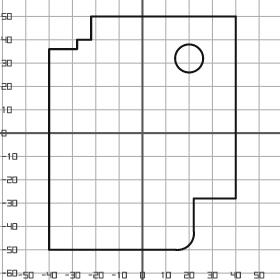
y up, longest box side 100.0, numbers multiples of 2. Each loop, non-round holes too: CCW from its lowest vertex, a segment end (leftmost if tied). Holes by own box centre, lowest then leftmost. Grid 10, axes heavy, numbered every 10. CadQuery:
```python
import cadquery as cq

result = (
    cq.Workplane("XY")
    .moveTo(-40.0, -50.0)
    .lineTo(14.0, -50.0)
    .threePointArc((20.0, -48.0), (22.0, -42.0))
    .lineTo(22.0, -28.0)
    .lineTo(40.0, -28.0)
    .lineTo(40.0, 50.0)
    .lineTo(-22.0, 50.0)
    .lineTo(-22.0, 40.0)
    .lineTo(-28.0, 40.0)
    .lineTo(-28.0, 36.0)
    .lineTo(-40.0, 36.0)
    .close()
    .moveTo(20.0, 32.0)
    .circle(6.0)
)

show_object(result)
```